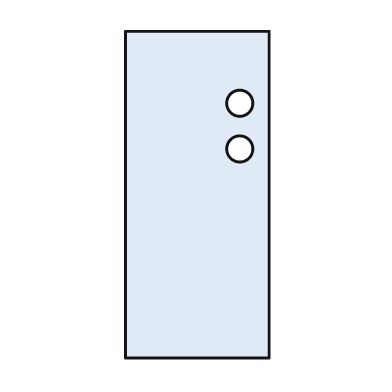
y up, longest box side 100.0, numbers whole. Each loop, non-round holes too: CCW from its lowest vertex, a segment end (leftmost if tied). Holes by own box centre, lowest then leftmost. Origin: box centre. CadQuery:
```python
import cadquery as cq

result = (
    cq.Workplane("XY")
    .moveTo(-22.0, -50.0)
    .lineTo(22.0, -50.0)
    .lineTo(22.0, 50.0)
    .lineTo(-22.0, 50.0)
    .close()
    .moveTo(13.0, 14.0)
    .circle(4.0)
    .moveTo(13.0, 28.0)
    .circle(4.0)
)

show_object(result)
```